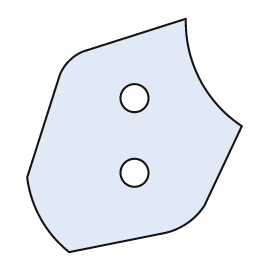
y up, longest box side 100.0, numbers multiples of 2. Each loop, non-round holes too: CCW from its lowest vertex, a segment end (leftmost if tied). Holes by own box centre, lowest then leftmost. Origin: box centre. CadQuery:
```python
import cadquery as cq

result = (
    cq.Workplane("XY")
    .moveTo(-28.0, -50.0)
    .lineTo(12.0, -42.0)
    .threePointArc((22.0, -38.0), (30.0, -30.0))
    .lineTo(46.0, 4.0)
    .threePointArc((28.0, 24.0), (22.0, 50.0))
    .lineTo(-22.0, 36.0)
    .threePointArc((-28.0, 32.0), (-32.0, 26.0))
    .lineTo(-46.0, -18.0)
    .threePointArc((-40.0, -36.0), (-28.0, -50.0))
    .close()
    .moveTo(0.0, -16.0)
    .circle(6.0)
    .moveTo(0.0, 16.0)
    .circle(6.0)
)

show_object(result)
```